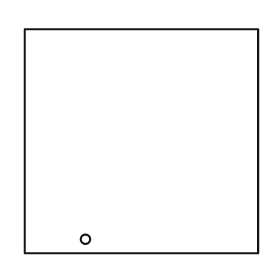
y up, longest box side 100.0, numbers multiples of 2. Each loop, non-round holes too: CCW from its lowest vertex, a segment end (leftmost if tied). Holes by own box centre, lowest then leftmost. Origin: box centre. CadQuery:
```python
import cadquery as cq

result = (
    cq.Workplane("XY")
    .moveTo(-50.0, -48.0)
    .lineTo(50.0, -48.0)
    .lineTo(50.0, 48.0)
    .lineTo(-50.0, 48.0)
    .close()
    .moveTo(-24.0, -42.0)
    .circle(2.0)
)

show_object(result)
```